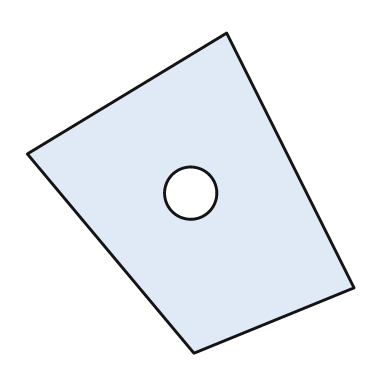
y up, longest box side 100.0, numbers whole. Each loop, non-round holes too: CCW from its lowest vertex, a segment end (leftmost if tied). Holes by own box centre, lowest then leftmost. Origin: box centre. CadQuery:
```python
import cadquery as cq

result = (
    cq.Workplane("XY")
    .moveTo(1.0, -49.0)
    .lineTo(50.0, -29.0)
    .lineTo(11.0, 49.0)
    .lineTo(-50.0, 12.0)
    .close()
    .moveTo(0.0, 0.0)
    .circle(8.0)
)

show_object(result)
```